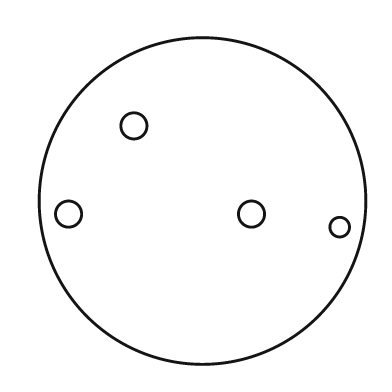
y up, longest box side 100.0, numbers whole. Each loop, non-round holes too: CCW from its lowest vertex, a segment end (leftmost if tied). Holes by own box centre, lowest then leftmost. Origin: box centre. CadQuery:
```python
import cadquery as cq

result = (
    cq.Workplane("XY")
    .moveTo(0.0, 0.0)
    .circle(50.0)
    .moveTo(42.0, -8.0)
    .circle(3.0)
    .moveTo(-41.0, -4.0)
    .circle(4.0)
    .moveTo(15.0, -4.0)
    .circle(4.0)
    .moveTo(-21.0, 23.0)
    .circle(4.0)
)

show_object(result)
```